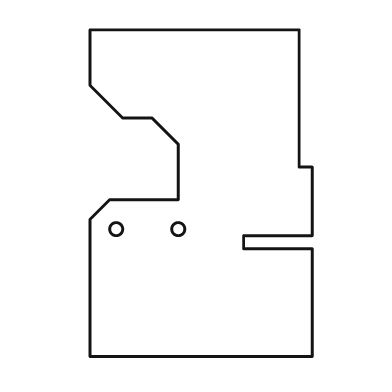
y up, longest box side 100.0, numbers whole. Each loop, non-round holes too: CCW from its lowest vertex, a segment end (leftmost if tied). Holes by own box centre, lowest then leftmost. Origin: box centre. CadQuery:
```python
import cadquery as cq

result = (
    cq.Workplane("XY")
    .moveTo(-34.0, -50.0)
    .lineTo(34.0, -50.0)
    .lineTo(34.0, -17.0)
    .lineTo(13.0, -17.0)
    .lineTo(13.0, -13.0)
    .lineTo(34.0, -13.0)
    .lineTo(34.0, 8.0)
    .lineTo(30.0, 8.0)
    .lineTo(30.0, 50.0)
    .lineTo(-34.0, 50.0)
    .lineTo(-34.0, 33.0)
    .lineTo(-24.0, 23.0)
    .lineTo(-15.0, 23.0)
    .lineTo(-7.0, 15.0)
    .lineTo(-7.0, -2.0)
    .lineTo(-28.0, -2.0)
    .lineTo(-34.0, -8.0)
    .close()
    .moveTo(-26.0, -11.0)
    .circle(2.0)
    .moveTo(-7.0, -11.0)
    .circle(2.0)
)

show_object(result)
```